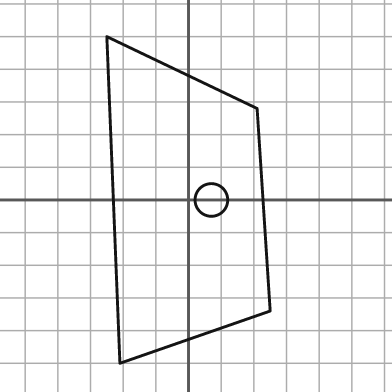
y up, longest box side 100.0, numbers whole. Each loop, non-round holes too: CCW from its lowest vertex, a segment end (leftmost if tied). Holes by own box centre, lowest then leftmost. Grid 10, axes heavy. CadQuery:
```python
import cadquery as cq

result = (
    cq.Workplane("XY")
    .moveTo(-21.0, -50.0)
    .lineTo(25.0, -34.0)
    .lineTo(21.0, 28.0)
    .lineTo(-25.0, 50.0)
    .close()
    .moveTo(7.0, 0.0)
    .circle(5.0)
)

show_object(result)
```